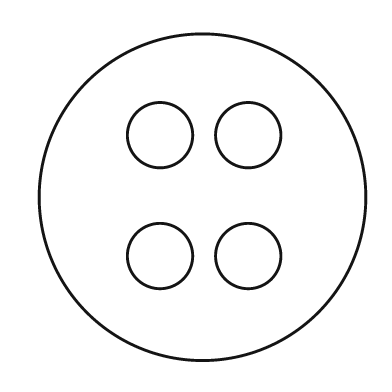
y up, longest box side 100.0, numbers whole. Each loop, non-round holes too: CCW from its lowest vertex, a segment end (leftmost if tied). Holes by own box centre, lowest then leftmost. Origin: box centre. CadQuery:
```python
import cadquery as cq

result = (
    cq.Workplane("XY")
    .moveTo(0.0, 0.0)
    .circle(50.0)
    .moveTo(-13.0, -18.0)
    .circle(10.0)
    .moveTo(14.0, -18.0)
    .circle(10.0)
    .moveTo(-13.0, 19.0)
    .circle(10.0)
    .moveTo(14.0, 19.0)
    .circle(10.0)
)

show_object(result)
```